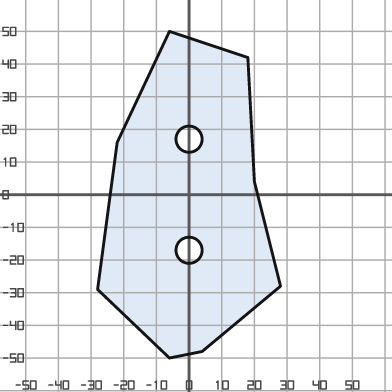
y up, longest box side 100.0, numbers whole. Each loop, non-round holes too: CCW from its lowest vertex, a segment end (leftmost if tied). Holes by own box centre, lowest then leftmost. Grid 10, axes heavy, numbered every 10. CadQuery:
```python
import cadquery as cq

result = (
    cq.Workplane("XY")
    .moveTo(-6.0, -50.0)
    .lineTo(4.0, -48.0)
    .lineTo(28.0, -28.0)
    .lineTo(20.0, 4.0)
    .lineTo(18.0, 42.0)
    .lineTo(-6.0, 50.0)
    .lineTo(-22.0, 16.0)
    .lineTo(-28.0, -29.0)
    .close()
    .moveTo(0.0, -17.0)
    .circle(4.0)
    .moveTo(0.0, 17.0)
    .circle(4.0)
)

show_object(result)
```